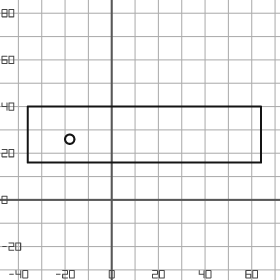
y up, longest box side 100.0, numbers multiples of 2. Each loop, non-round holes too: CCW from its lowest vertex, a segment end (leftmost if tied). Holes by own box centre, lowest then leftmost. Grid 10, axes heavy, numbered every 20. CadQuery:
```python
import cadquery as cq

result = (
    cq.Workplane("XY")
    .moveTo(-36.0, 16.0)
    .lineTo(64.0, 16.0)
    .lineTo(64.0, 40.0)
    .lineTo(-36.0, 40.0)
    .close()
    .moveTo(-18.0, 26.0)
    .circle(2.0)
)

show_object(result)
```